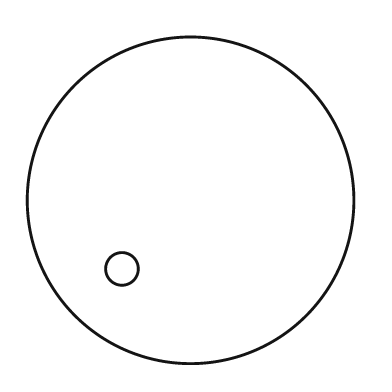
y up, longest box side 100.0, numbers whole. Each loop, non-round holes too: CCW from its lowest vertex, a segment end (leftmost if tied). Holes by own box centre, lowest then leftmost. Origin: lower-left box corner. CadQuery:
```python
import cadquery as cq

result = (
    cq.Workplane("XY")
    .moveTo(50.0, 50.0)
    .circle(50.0)
    .moveTo(29.0, 29.0)
    .circle(5.0)
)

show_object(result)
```